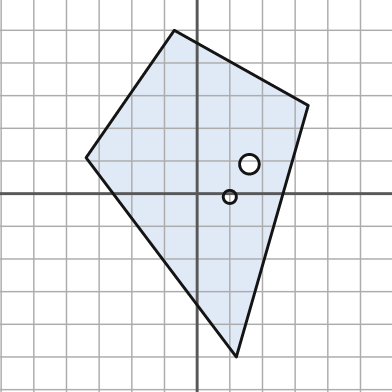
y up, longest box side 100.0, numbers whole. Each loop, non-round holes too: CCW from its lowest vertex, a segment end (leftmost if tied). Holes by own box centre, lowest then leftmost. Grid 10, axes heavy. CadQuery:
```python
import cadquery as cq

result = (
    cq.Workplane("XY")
    .moveTo(12.0, -50.0)
    .lineTo(34.0, 27.0)
    .lineTo(-7.0, 50.0)
    .lineTo(-34.0, 11.0)
    .close()
    .moveTo(10.0, -1.0)
    .circle(2.0)
    .moveTo(16.0, 9.0)
    .circle(3.0)
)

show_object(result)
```